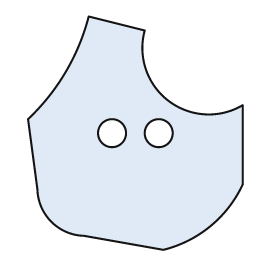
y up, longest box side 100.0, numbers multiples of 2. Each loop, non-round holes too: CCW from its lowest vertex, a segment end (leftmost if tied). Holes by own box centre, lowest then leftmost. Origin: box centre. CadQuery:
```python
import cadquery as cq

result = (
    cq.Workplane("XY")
    .moveTo(12.0, -50.0)
    .threePointArc((32.0, -40.0), (46.0, -22.0))
    .lineTo(46.0, 12.0)
    .threePointArc((14.0, 14.0), (4.0, 44.0))
    .lineTo(-20.0, 50.0)
    .threePointArc((-30.0, 26.0), (-46.0, 6.0))
    .lineTo(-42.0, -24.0)
    .threePointArc((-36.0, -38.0), (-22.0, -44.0))
    .close()
    .moveTo(-10.0, 0.0)
    .circle(6.0)
    .moveTo(10.0, 0.0)
    .circle(6.0)
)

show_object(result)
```